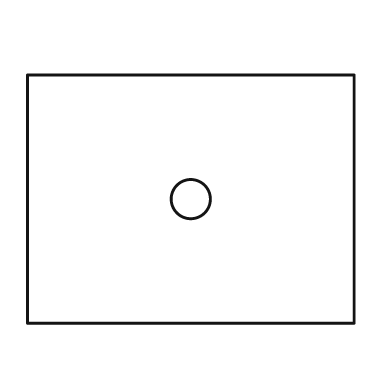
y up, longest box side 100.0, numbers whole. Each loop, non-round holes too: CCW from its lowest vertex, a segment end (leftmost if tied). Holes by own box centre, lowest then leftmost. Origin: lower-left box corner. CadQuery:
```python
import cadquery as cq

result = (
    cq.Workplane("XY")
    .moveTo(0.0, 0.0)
    .lineTo(100.0, 0.0)
    .lineTo(100.0, 76.0)
    .lineTo(0.0, 76.0)
    .close()
    .moveTo(50.0, 38.0)
    .circle(6.0)
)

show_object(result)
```